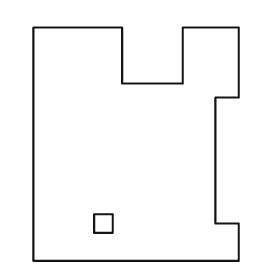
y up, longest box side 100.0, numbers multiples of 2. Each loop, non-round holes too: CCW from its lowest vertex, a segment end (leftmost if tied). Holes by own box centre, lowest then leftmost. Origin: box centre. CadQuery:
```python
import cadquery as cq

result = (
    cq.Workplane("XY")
    .moveTo(-44.0, -50.0)
    .lineTo(44.0, -50.0)
    .lineTo(44.0, -34.0)
    .lineTo(34.0, -34.0)
    .lineTo(34.0, 20.0)
    .lineTo(44.0, 20.0)
    .lineTo(44.0, 50.0)
    .lineTo(20.0, 50.0)
    .lineTo(20.0, 26.0)
    .lineTo(-6.0, 26.0)
    .lineTo(-6.0, 50.0)
    .lineTo(-44.0, 50.0)
    .close()
    .moveTo(-18.0, -38.0)
    .lineTo(-10.0, -38.0)
    .lineTo(-10.0, -30.0)
    .lineTo(-18.0, -30.0)
    .close()
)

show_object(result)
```